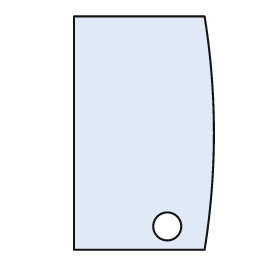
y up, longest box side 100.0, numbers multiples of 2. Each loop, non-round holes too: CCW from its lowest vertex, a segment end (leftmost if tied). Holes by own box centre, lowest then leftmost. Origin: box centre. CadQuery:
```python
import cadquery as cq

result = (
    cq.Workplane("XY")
    .moveTo(-30.0, -50.0)
    .lineTo(26.0, -50.0)
    .threePointArc((30.0, 0.0), (26.0, 50.0))
    .lineTo(-30.0, 50.0)
    .close()
    .moveTo(10.0, -40.0)
    .circle(6.0)
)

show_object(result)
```